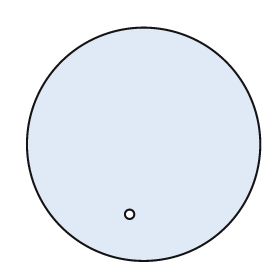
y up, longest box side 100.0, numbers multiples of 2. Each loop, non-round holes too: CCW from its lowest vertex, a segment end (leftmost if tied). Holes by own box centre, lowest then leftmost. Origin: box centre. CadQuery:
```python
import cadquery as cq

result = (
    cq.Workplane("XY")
    .moveTo(0.0, 0.0)
    .circle(50.0)
    .moveTo(-6.0, -30.0)
    .circle(2.0)
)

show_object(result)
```